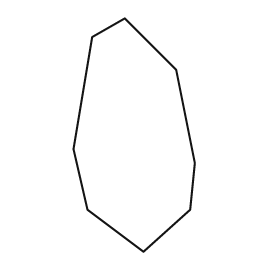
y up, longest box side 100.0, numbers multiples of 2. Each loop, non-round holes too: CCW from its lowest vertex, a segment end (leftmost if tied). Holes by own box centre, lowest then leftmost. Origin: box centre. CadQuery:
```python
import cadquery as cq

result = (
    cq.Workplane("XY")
    .moveTo(4.0, -50.0)
    .lineTo(24.0, -32.0)
    .lineTo(26.0, -12.0)
    .lineTo(18.0, 28.0)
    .lineTo(-4.0, 50.0)
    .lineTo(-18.0, 42.0)
    .lineTo(-26.0, -6.0)
    .lineTo(-20.0, -32.0)
    .close()
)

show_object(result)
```